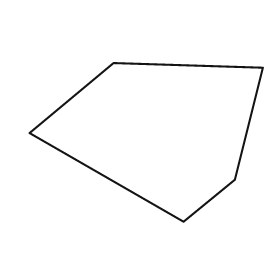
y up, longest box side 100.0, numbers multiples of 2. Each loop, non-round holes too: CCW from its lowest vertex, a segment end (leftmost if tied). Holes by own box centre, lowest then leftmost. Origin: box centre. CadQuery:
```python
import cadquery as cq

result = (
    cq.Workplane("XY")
    .moveTo(16.0, -34.0)
    .lineTo(38.0, -16.0)
    .lineTo(50.0, 32.0)
    .lineTo(-14.0, 34.0)
    .lineTo(-50.0, 4.0)
    .close()
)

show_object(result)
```